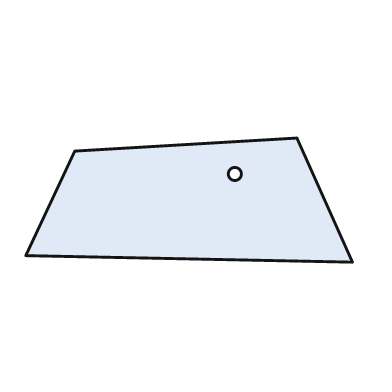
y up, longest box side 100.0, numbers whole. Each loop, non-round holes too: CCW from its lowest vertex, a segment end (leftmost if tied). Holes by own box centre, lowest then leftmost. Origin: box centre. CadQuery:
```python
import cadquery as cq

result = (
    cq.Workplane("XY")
    .moveTo(50.0, -19.0)
    .lineTo(33.0, 19.0)
    .lineTo(-35.0, 15.0)
    .lineTo(-50.0, -17.0)
    .close()
    .moveTo(14.0, 8.0)
    .circle(2.0)
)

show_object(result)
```